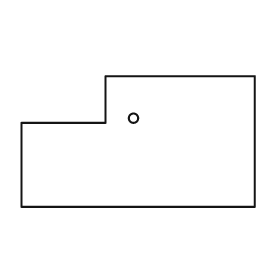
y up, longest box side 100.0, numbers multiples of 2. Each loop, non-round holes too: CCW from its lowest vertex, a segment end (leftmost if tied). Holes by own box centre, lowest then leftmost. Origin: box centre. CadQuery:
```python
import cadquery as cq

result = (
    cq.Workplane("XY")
    .moveTo(-50.0, -28.0)
    .lineTo(50.0, -28.0)
    .lineTo(50.0, 28.0)
    .lineTo(-14.0, 28.0)
    .lineTo(-14.0, 8.0)
    .lineTo(-50.0, 8.0)
    .close()
    .moveTo(-2.0, 10.0)
    .circle(2.0)
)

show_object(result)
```